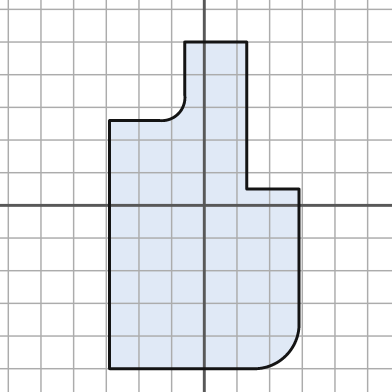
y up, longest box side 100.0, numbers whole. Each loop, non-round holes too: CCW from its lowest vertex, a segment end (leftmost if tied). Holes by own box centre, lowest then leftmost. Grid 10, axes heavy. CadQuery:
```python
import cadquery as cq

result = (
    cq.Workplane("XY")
    .moveTo(-29.0, -50.0)
    .lineTo(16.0, -50.0)
    .threePointArc((25.0, -46.0), (29.0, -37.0))
    .lineTo(29.0, 5.0)
    .lineTo(13.0, 5.0)
    .lineTo(13.0, 50.0)
    .lineTo(-6.0, 50.0)
    .lineTo(-6.0, 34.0)
    .threePointArc((-8.0, 28.0), (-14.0, 26.0))
    .lineTo(-29.0, 26.0)
    .close()
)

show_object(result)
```